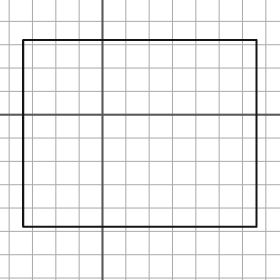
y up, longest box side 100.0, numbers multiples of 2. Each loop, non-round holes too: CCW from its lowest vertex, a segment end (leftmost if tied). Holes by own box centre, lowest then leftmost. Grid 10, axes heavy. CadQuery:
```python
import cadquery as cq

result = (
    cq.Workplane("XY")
    .moveTo(-34.0, -48.0)
    .lineTo(66.0, -48.0)
    .lineTo(66.0, 32.0)
    .lineTo(-34.0, 32.0)
    .close()
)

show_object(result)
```